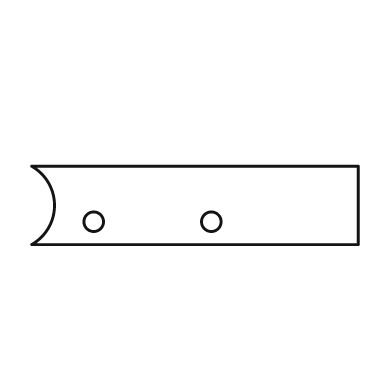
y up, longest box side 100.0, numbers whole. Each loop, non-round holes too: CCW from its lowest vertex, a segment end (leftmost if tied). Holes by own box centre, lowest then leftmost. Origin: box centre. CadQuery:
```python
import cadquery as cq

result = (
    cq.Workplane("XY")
    .moveTo(-50.0, -12.0)
    .lineTo(50.0, -12.0)
    .lineTo(50.0, 12.0)
    .lineTo(-50.0, 12.0)
    .threePointArc((-43.0, 0.0), (-50.0, -12.0))
    .close()
    .moveTo(-31.0, -5.0)
    .circle(3.0)
    .moveTo(5.0, -5.0)
    .circle(3.0)
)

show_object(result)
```